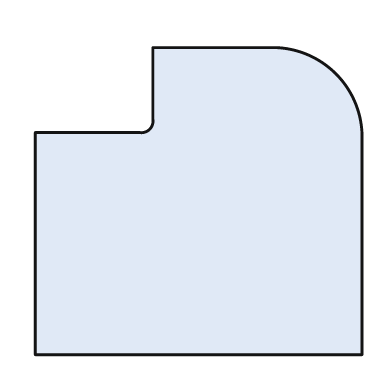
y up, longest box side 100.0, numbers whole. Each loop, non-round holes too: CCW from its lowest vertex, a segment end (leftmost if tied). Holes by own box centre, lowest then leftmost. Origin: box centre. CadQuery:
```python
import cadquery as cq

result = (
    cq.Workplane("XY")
    .moveTo(-50.0, -47.0)
    .lineTo(50.0, -47.0)
    .lineTo(50.0, 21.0)
    .threePointArc((42.0, 39.0), (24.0, 47.0))
    .lineTo(-14.0, 47.0)
    .lineTo(-14.0, 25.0)
    .threePointArc((-15.0, 22.0), (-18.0, 21.0))
    .lineTo(-50.0, 21.0)
    .close()
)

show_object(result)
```